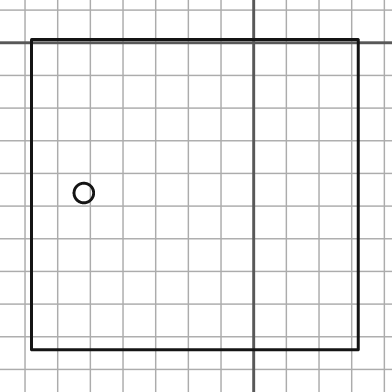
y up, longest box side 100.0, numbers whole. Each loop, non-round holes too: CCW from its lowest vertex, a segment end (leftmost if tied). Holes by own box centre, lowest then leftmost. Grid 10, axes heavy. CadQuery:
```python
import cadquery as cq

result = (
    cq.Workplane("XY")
    .moveTo(-68.0, -94.0)
    .lineTo(32.0, -94.0)
    .lineTo(32.0, 1.0)
    .lineTo(-68.0, 1.0)
    .close()
    .moveTo(-52.0, -46.0)
    .circle(3.0)
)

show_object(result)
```